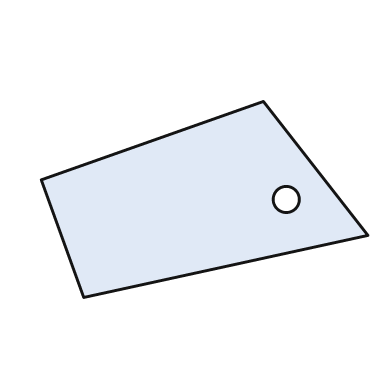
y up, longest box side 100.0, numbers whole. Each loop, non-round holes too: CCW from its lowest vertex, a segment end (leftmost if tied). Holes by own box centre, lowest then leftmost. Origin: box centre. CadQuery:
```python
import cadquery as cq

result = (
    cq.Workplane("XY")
    .moveTo(-37.0, -30.0)
    .lineTo(50.0, -11.0)
    .lineTo(18.0, 30.0)
    .lineTo(-50.0, 6.0)
    .close()
    .moveTo(25.0, 0.0)
    .circle(4.0)
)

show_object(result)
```